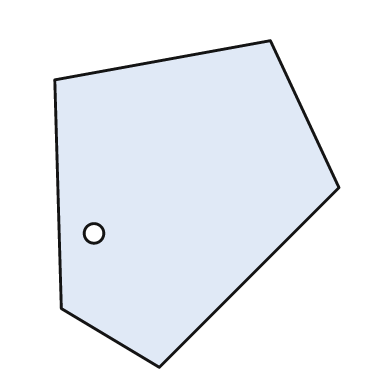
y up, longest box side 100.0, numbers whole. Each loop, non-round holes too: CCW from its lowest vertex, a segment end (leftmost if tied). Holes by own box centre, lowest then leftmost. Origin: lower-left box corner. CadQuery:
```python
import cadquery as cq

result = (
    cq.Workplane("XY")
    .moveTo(32.0, 0.0)
    .lineTo(87.0, 55.0)
    .lineTo(66.0, 100.0)
    .lineTo(0.0, 88.0)
    .lineTo(2.0, 18.0)
    .close()
    .moveTo(12.0, 41.0)
    .circle(3.0)
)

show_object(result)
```